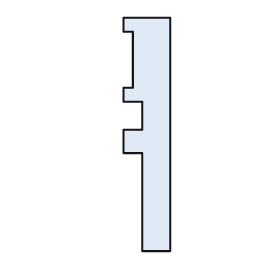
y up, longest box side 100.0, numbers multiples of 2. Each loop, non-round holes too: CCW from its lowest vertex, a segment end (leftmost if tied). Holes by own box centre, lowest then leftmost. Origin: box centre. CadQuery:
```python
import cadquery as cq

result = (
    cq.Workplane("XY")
    .moveTo(-2.0, -50.0)
    .lineTo(10.0, -50.0)
    .lineTo(10.0, 50.0)
    .lineTo(-10.0, 50.0)
    .lineTo(-10.0, 44.0)
    .lineTo(-6.0, 44.0)
    .lineTo(-6.0, 20.0)
    .lineTo(-10.0, 20.0)
    .lineTo(-10.0, 14.0)
    .lineTo(-2.0, 14.0)
    .lineTo(-2.0, 2.0)
    .lineTo(-10.0, 2.0)
    .lineTo(-10.0, -8.0)
    .lineTo(-2.0, -8.0)
    .close()
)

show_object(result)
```